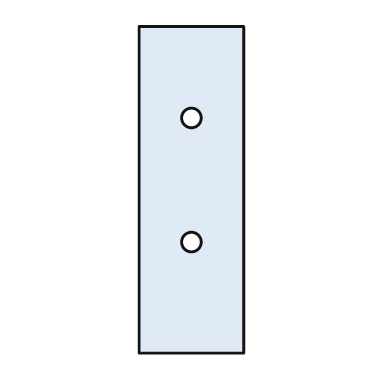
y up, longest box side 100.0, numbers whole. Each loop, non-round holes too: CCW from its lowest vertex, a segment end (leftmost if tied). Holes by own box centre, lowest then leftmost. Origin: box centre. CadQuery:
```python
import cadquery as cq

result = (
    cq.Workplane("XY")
    .moveTo(-16.0, -50.0)
    .lineTo(16.0, -50.0)
    .lineTo(16.0, 50.0)
    .lineTo(-16.0, 50.0)
    .close()
    .moveTo(0.0, -16.0)
    .circle(3.0)
    .moveTo(0.0, 22.0)
    .circle(3.0)
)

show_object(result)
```